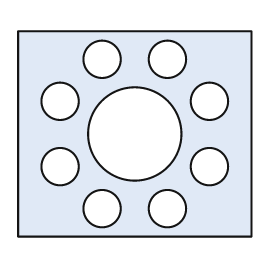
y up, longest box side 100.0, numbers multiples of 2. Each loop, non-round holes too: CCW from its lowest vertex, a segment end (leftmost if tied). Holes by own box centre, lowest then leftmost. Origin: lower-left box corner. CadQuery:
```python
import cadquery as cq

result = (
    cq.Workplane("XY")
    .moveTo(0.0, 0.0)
    .lineTo(100.0, 0.0)
    .lineTo(100.0, 88.0)
    .lineTo(0.0, 88.0)
    .close()
    .moveTo(36.0, 12.0)
    .circle(8.0)
    .moveTo(64.0, 12.0)
    .circle(8.0)
    .moveTo(18.0, 30.0)
    .circle(8.0)
    .moveTo(82.0, 30.0)
    .circle(8.0)
    .moveTo(50.0, 44.0)
    .circle(20.0)
    .moveTo(18.0, 58.0)
    .circle(8.0)
    .moveTo(82.0, 58.0)
    .circle(8.0)
    .moveTo(36.0, 76.0)
    .circle(8.0)
    .moveTo(64.0, 76.0)
    .circle(8.0)
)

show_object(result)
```